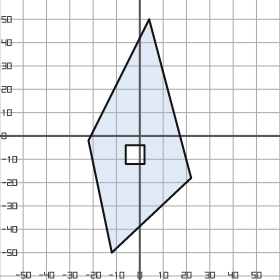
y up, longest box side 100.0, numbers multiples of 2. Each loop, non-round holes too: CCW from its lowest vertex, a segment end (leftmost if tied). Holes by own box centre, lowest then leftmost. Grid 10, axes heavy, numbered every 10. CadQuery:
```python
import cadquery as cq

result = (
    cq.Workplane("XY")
    .moveTo(-12.0, -50.0)
    .lineTo(22.0, -18.0)
    .lineTo(4.0, 50.0)
    .lineTo(-22.0, -2.0)
    .close()
    .moveTo(-6.0, -12.0)
    .lineTo(2.0, -12.0)
    .lineTo(2.0, -4.0)
    .lineTo(-6.0, -4.0)
    .close()
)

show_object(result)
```